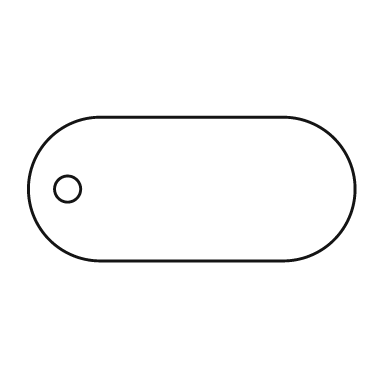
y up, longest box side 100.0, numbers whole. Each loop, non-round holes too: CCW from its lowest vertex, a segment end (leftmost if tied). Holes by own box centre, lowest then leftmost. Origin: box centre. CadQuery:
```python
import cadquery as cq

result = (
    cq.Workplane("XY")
    .moveTo(-28.0, -22.0)
    .lineTo(28.0, -22.0)
    .threePointArc((50.0, 0.0), (28.0, 22.0))
    .lineTo(-28.0, 22.0)
    .threePointArc((-50.0, 0.0), (-28.0, -22.0))
    .close()
    .moveTo(-38.0, 0.0)
    .circle(4.0)
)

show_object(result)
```